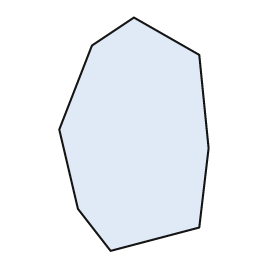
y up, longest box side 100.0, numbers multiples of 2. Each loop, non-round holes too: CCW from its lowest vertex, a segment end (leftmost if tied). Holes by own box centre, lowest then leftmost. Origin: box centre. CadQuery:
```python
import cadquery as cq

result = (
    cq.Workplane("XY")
    .moveTo(-10.0, -50.0)
    .lineTo(28.0, -40.0)
    .lineTo(32.0, -6.0)
    .lineTo(28.0, 34.0)
    .lineTo(0.0, 50.0)
    .lineTo(-18.0, 38.0)
    .lineTo(-32.0, 2.0)
    .lineTo(-24.0, -32.0)
    .close()
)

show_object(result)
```